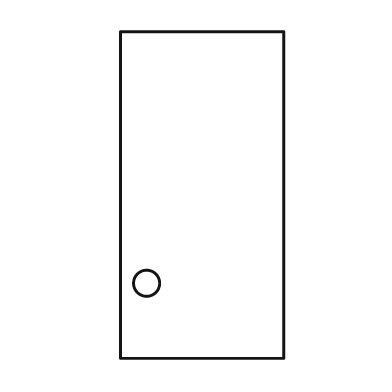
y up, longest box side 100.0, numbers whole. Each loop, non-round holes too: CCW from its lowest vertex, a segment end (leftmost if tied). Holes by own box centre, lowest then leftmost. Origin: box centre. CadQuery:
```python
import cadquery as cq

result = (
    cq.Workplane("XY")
    .moveTo(-25.0, -50.0)
    .lineTo(25.0, -50.0)
    .lineTo(25.0, 50.0)
    .lineTo(-25.0, 50.0)
    .close()
    .moveTo(-17.0, -27.0)
    .circle(4.0)
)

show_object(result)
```